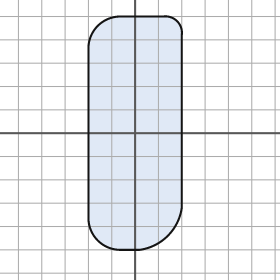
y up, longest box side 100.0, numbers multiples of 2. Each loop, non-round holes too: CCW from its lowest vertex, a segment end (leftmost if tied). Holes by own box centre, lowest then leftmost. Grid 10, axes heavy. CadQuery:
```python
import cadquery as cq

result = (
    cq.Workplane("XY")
    .moveTo(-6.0, -50.0)
    .lineTo(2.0, -50.0)
    .threePointArc((14.0, -44.0), (20.0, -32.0))
    .lineTo(20.0, 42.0)
    .threePointArc((18.0, 48.0), (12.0, 50.0))
    .lineTo(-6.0, 50.0)
    .threePointArc((-16.0, 46.0), (-20.0, 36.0))
    .lineTo(-20.0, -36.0)
    .threePointArc((-16.0, -46.0), (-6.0, -50.0))
    .close()
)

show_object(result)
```